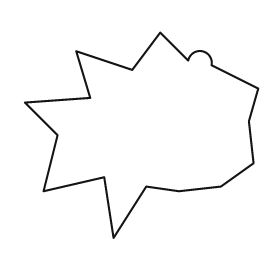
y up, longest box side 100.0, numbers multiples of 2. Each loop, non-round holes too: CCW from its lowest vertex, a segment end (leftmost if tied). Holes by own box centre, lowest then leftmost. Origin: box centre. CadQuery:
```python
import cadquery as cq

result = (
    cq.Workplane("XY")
    .moveTo(-12.0, -44.0)
    .lineTo(2.0, -22.0)
    .lineTo(16.0, -24.0)
    .lineTo(34.0, -22.0)
    .lineTo(48.0, -12.0)
    .lineTo(46.0, 6.0)
    .lineTo(50.0, 20.0)
    .lineTo(30.0, 30.0)
    .threePointArc((26.0, 36.0), (20.0, 32.0))
    .lineTo(8.0, 44.0)
    .lineTo(-4.0, 28.0)
    .lineTo(-28.0, 36.0)
    .lineTo(-22.0, 16.0)
    .lineTo(-50.0, 14.0)
    .lineTo(-36.0, 0.0)
    .lineTo(-42.0, -24.0)
    .lineTo(-16.0, -18.0)
    .close()
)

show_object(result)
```